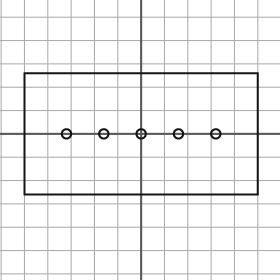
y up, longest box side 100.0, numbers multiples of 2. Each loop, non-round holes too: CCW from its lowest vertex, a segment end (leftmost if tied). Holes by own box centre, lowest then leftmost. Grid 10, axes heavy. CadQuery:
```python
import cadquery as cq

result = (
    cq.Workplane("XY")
    .moveTo(-50.0, -26.0)
    .lineTo(50.0, -26.0)
    .lineTo(50.0, 26.0)
    .lineTo(-50.0, 26.0)
    .close()
    .moveTo(-32.0, 0.0)
    .circle(2.0)
    .moveTo(-16.0, 0.0)
    .circle(2.0)
    .moveTo(0.0, 0.0)
    .circle(2.0)
    .moveTo(16.0, 0.0)
    .circle(2.0)
    .moveTo(32.0, 0.0)
    .circle(2.0)
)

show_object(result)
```